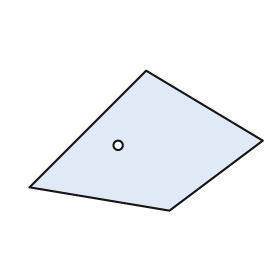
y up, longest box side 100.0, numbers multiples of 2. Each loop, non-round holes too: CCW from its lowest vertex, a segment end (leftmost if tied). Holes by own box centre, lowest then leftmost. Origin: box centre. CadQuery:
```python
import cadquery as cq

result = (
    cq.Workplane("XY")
    .moveTo(10.0, -30.0)
    .lineTo(50.0, 0.0)
    .lineTo(0.0, 30.0)
    .lineTo(-50.0, -20.0)
    .close()
    .moveTo(-12.0, -2.0)
    .circle(2.0)
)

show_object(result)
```